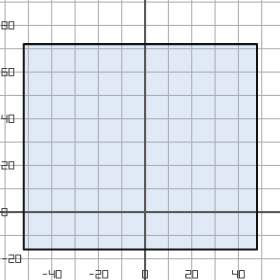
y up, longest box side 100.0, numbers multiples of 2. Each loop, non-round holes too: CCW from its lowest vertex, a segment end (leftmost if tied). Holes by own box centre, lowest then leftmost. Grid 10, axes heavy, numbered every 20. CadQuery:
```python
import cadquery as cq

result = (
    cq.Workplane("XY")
    .moveTo(-52.0, -16.0)
    .lineTo(48.0, -16.0)
    .lineTo(48.0, 72.0)
    .lineTo(-52.0, 72.0)
    .close()
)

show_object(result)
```